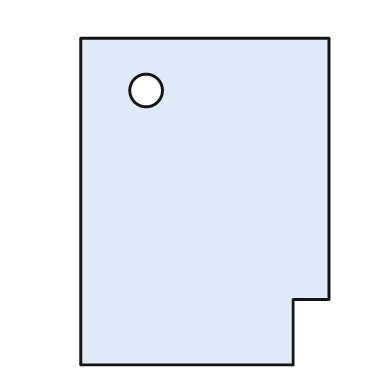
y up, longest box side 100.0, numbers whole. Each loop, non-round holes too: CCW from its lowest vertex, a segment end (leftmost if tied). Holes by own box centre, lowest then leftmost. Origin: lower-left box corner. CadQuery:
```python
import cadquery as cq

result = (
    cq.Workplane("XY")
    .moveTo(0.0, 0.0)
    .lineTo(65.0, 0.0)
    .lineTo(65.0, 20.0)
    .lineTo(76.0, 20.0)
    .lineTo(76.0, 100.0)
    .lineTo(0.0, 100.0)
    .close()
    .moveTo(20.0, 84.0)
    .circle(5.0)
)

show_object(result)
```